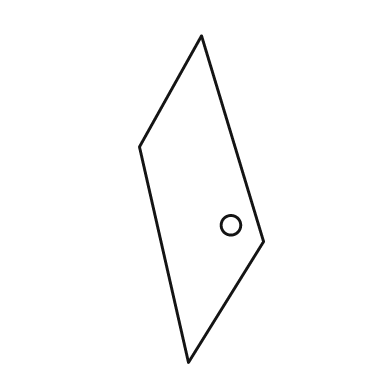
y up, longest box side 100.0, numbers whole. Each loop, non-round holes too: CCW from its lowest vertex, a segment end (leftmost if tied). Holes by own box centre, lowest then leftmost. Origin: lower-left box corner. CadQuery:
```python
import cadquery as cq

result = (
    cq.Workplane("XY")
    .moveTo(15.0, 0.0)
    .lineTo(38.0, 37.0)
    .lineTo(19.0, 100.0)
    .lineTo(0.0, 66.0)
    .close()
    .moveTo(28.0, 42.0)
    .circle(3.0)
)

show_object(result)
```